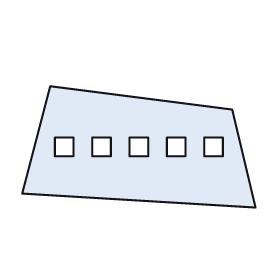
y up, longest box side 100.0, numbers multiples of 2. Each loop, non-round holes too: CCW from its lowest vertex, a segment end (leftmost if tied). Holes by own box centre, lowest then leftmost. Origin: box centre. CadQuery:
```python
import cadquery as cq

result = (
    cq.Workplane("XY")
    .moveTo(50.0, -26.0)
    .lineTo(40.0, 16.0)
    .lineTo(-38.0, 26.0)
    .lineTo(-50.0, -20.0)
    .close()
    .moveTo(-36.0, -4.0)
    .lineTo(-28.0, -4.0)
    .lineTo(-28.0, 4.0)
    .lineTo(-36.0, 4.0)
    .close()
    .moveTo(-20.0, -4.0)
    .lineTo(-12.0, -4.0)
    .lineTo(-12.0, 4.0)
    .lineTo(-20.0, 4.0)
    .close()
    .moveTo(-4.0, -4.0)
    .lineTo(4.0, -4.0)
    .lineTo(4.0, 4.0)
    .lineTo(-4.0, 4.0)
    .close()
    .moveTo(12.0, -4.0)
    .lineTo(20.0, -4.0)
    .lineTo(20.0, 4.0)
    .lineTo(12.0, 4.0)
    .close()
    .moveTo(28.0, -4.0)
    .lineTo(36.0, -4.0)
    .lineTo(36.0, 4.0)
    .lineTo(28.0, 4.0)
    .close()
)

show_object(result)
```